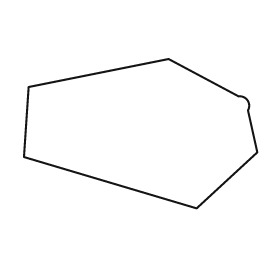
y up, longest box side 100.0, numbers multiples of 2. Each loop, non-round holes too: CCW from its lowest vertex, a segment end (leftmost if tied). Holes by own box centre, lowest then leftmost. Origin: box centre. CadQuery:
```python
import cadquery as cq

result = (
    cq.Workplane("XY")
    .moveTo(24.0, -32.0)
    .lineTo(50.0, -8.0)
    .lineTo(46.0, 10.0)
    .threePointArc((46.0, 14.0), (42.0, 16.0))
    .lineTo(12.0, 32.0)
    .lineTo(-48.0, 20.0)
    .lineTo(-50.0, -10.0)
    .close()
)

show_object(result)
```